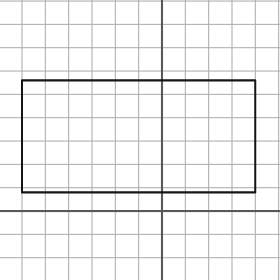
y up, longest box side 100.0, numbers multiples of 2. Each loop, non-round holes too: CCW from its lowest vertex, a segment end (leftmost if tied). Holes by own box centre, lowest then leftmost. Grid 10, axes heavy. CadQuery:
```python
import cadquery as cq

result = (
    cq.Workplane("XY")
    .moveTo(-60.0, 8.0)
    .lineTo(40.0, 8.0)
    .lineTo(40.0, 56.0)
    .lineTo(-60.0, 56.0)
    .close()
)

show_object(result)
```